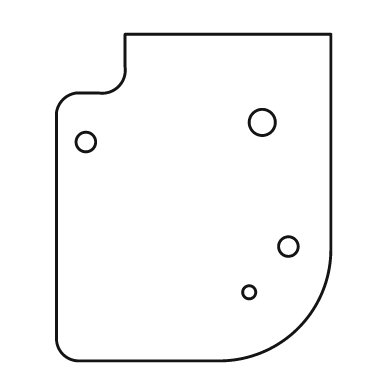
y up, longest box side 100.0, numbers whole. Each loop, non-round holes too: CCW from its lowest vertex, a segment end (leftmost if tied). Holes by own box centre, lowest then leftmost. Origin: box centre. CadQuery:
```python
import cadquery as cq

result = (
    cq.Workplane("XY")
    .moveTo(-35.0, -50.0)
    .lineTo(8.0, -50.0)
    .threePointArc((32.0, -40.0), (42.0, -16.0))
    .lineTo(42.0, 50.0)
    .lineTo(-21.0, 50.0)
    .lineTo(-21.0, 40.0)
    .threePointArc((-23.0, 34.0), (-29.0, 32.0))
    .lineTo(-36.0, 32.0)
    .threePointArc((-40.0, 30.0), (-42.0, 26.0))
    .lineTo(-42.0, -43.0)
    .threePointArc((-40.0, -48.0), (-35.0, -50.0))
    .close()
    .moveTo(17.0, -29.0)
    .circle(2.0)
    .moveTo(29.0, -15.0)
    .circle(3.0)
    .moveTo(-33.0, 17.0)
    .circle(3.0)
    .moveTo(21.0, 23.0)
    .circle(4.0)
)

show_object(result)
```